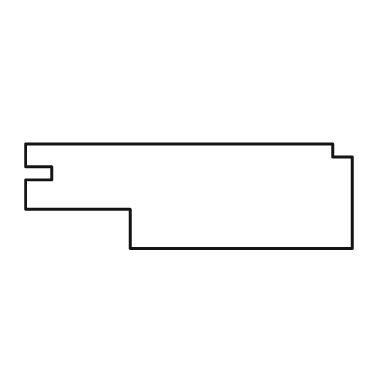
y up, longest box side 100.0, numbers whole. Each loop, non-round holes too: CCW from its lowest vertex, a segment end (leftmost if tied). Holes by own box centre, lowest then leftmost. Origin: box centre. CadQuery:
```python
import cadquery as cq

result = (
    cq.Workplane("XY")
    .moveTo(-18.0, -16.0)
    .lineTo(50.0, -16.0)
    .lineTo(50.0, 12.0)
    .lineTo(44.0, 12.0)
    .lineTo(44.0, 16.0)
    .lineTo(-50.0, 16.0)
    .lineTo(-50.0, 9.0)
    .lineTo(-42.0, 9.0)
    .lineTo(-42.0, 5.0)
    .lineTo(-50.0, 5.0)
    .lineTo(-50.0, -4.0)
    .lineTo(-18.0, -4.0)
    .close()
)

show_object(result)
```